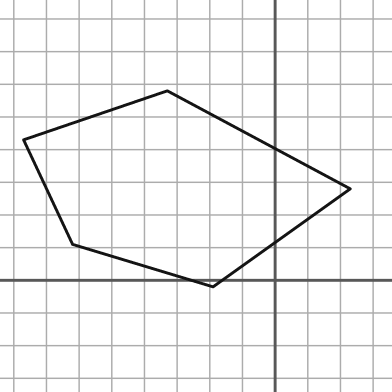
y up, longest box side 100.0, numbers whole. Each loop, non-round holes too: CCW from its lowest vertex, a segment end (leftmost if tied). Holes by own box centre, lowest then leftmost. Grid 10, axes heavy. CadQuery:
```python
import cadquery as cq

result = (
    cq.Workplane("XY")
    .moveTo(-19.0, -2.0)
    .lineTo(23.0, 28.0)
    .lineTo(-33.0, 58.0)
    .lineTo(-77.0, 43.0)
    .lineTo(-62.0, 11.0)
    .close()
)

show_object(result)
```